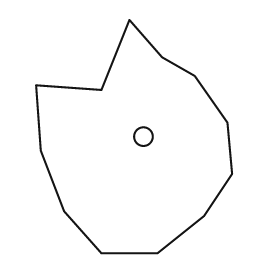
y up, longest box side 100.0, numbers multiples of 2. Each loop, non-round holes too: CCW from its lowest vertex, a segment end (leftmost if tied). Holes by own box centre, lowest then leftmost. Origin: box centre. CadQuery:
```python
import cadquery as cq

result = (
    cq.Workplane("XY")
    .moveTo(-14.0, -50.0)
    .lineTo(10.0, -50.0)
    .lineTo(30.0, -34.0)
    .lineTo(42.0, -16.0)
    .lineTo(40.0, 6.0)
    .lineTo(26.0, 26.0)
    .lineTo(12.0, 34.0)
    .lineTo(-2.0, 50.0)
    .lineTo(-14.0, 20.0)
    .lineTo(-42.0, 22.0)
    .lineTo(-40.0, -6.0)
    .lineTo(-30.0, -32.0)
    .close()
    .moveTo(4.0, 0.0)
    .circle(4.0)
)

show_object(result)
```